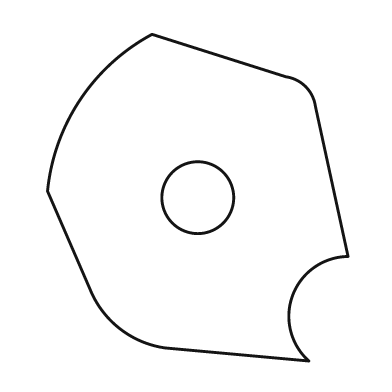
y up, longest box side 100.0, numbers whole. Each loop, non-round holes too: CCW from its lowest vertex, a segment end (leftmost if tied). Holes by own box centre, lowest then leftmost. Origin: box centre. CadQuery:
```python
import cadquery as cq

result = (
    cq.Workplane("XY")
    .moveTo(34.0, -50.0)
    .threePointArc((29.0, -30.0), (46.0, -18.0))
    .lineTo(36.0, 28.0)
    .threePointArc((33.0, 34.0), (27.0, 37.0))
    .lineTo(-14.0, 50.0)
    .threePointArc((-36.0, 30.0), (-46.0, 2.0))
    .lineTo(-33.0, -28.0)
    .threePointArc((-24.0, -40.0), (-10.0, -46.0))
    .close()
    .moveTo(0.0, 0.0)
    .circle(11.0)
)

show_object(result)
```